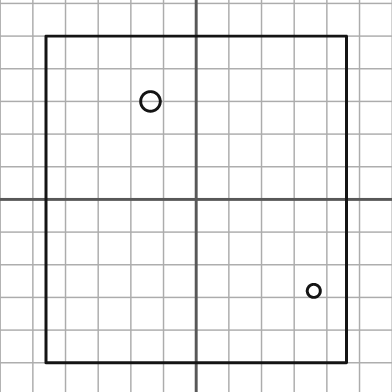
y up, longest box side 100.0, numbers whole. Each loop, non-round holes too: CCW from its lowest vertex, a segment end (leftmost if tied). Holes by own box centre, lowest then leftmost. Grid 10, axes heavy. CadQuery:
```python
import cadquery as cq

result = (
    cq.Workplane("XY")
    .moveTo(-46.0, -50.0)
    .lineTo(46.0, -50.0)
    .lineTo(46.0, 50.0)
    .lineTo(-46.0, 50.0)
    .close()
    .moveTo(36.0, -28.0)
    .circle(2.0)
    .moveTo(-14.0, 30.0)
    .circle(3.0)
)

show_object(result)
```